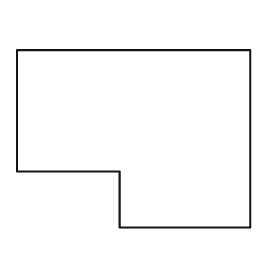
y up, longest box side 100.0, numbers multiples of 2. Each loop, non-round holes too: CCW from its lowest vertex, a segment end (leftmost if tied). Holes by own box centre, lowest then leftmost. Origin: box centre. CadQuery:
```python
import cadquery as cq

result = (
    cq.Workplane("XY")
    .moveTo(-6.0, -38.0)
    .lineTo(50.0, -38.0)
    .lineTo(50.0, 38.0)
    .lineTo(-50.0, 38.0)
    .lineTo(-50.0, -14.0)
    .lineTo(-6.0, -14.0)
    .close()
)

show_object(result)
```